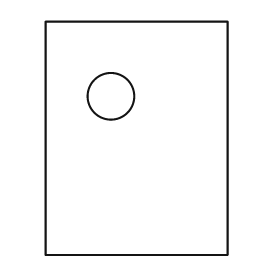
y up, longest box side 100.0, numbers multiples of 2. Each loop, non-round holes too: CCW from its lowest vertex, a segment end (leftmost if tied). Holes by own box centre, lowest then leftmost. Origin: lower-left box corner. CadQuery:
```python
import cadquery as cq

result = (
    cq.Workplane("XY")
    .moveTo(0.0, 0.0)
    .lineTo(78.0, 0.0)
    .lineTo(78.0, 100.0)
    .lineTo(0.0, 100.0)
    .close()
    .moveTo(28.0, 68.0)
    .circle(10.0)
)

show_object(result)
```